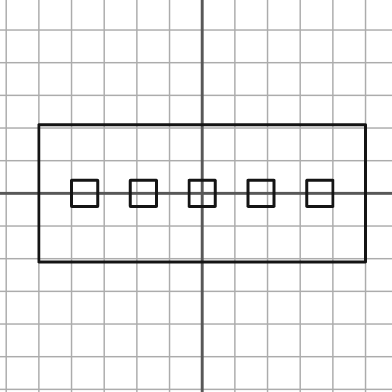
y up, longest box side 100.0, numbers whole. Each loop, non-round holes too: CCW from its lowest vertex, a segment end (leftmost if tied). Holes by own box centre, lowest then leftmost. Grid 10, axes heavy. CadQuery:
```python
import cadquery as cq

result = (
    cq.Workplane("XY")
    .moveTo(-50.0, -21.0)
    .lineTo(50.0, -21.0)
    .lineTo(50.0, 21.0)
    .lineTo(-50.0, 21.0)
    .close()
    .moveTo(-40.0, -4.0)
    .lineTo(-32.0, -4.0)
    .lineTo(-32.0, 4.0)
    .lineTo(-40.0, 4.0)
    .close()
    .moveTo(-22.0, -4.0)
    .lineTo(-14.0, -4.0)
    .lineTo(-14.0, 4.0)
    .lineTo(-22.0, 4.0)
    .close()
    .moveTo(-4.0, -4.0)
    .lineTo(4.0, -4.0)
    .lineTo(4.0, 4.0)
    .lineTo(-4.0, 4.0)
    .close()
    .moveTo(14.0, -4.0)
    .lineTo(22.0, -4.0)
    .lineTo(22.0, 4.0)
    .lineTo(14.0, 4.0)
    .close()
    .moveTo(32.0, -4.0)
    .lineTo(40.0, -4.0)
    .lineTo(40.0, 4.0)
    .lineTo(32.0, 4.0)
    .close()
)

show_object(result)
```